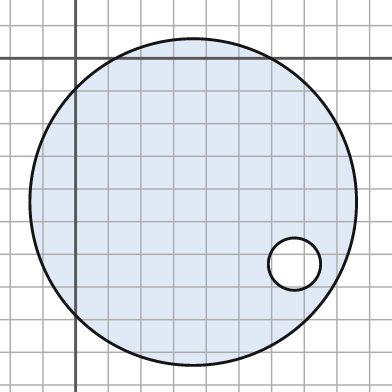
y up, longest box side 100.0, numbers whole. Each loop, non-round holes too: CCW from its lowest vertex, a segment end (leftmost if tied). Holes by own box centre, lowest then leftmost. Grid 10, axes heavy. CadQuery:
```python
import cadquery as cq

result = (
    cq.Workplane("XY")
    .moveTo(36.0, -44.0)
    .circle(50.0)
    .moveTo(67.0, -63.0)
    .circle(8.0)
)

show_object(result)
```